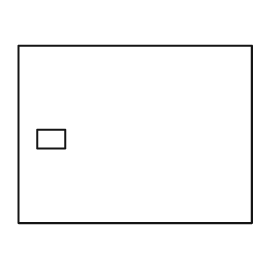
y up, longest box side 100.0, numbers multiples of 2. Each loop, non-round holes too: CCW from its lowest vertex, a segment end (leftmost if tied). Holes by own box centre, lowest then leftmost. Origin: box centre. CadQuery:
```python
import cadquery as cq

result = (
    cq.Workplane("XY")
    .moveTo(-50.0, -38.0)
    .lineTo(50.0, -38.0)
    .lineTo(50.0, 38.0)
    .lineTo(-50.0, 38.0)
    .close()
    .moveTo(-42.0, -6.0)
    .lineTo(-30.0, -6.0)
    .lineTo(-30.0, 2.0)
    .lineTo(-42.0, 2.0)
    .close()
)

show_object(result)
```